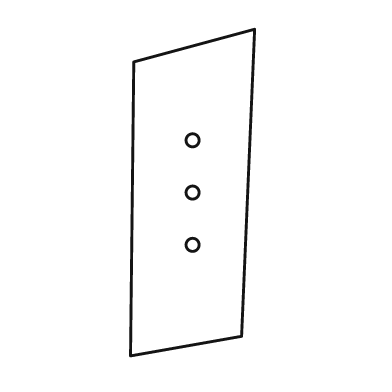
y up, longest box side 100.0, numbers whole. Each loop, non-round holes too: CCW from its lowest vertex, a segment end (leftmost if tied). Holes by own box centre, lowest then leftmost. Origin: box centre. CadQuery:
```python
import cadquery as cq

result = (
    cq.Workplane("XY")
    .moveTo(-19.0, -50.0)
    .lineTo(15.0, -44.0)
    .lineTo(19.0, 50.0)
    .lineTo(-18.0, 40.0)
    .close()
    .moveTo(0.0, -16.0)
    .circle(2.0)
    .moveTo(0.0, 0.0)
    .circle(2.0)
    .moveTo(0.0, 16.0)
    .circle(2.0)
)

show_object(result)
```